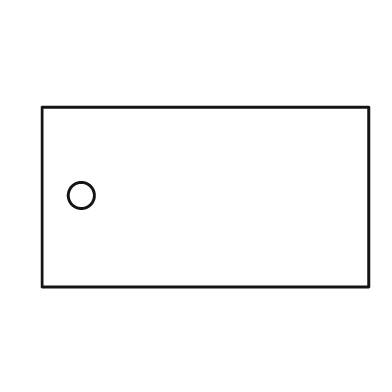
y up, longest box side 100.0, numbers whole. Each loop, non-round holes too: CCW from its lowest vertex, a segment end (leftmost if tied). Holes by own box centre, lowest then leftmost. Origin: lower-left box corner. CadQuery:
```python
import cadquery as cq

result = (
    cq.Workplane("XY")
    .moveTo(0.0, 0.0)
    .lineTo(100.0, 0.0)
    .lineTo(100.0, 55.0)
    .lineTo(0.0, 55.0)
    .close()
    .moveTo(12.0, 28.0)
    .circle(4.0)
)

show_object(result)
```